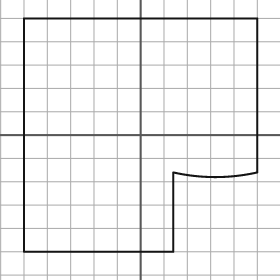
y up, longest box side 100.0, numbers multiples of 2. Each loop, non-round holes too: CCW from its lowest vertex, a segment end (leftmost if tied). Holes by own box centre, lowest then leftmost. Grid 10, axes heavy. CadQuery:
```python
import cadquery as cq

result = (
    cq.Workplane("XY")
    .moveTo(-50.0, -50.0)
    .lineTo(14.0, -50.0)
    .lineTo(14.0, -16.0)
    .threePointArc((32.0, -18.0), (50.0, -16.0))
    .lineTo(50.0, 50.0)
    .lineTo(-50.0, 50.0)
    .close()
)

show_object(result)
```